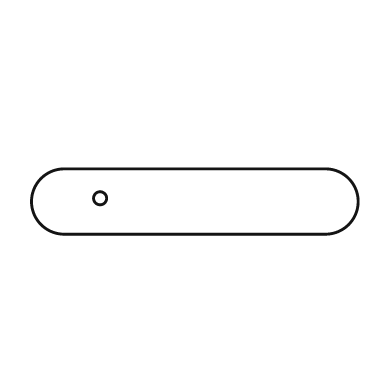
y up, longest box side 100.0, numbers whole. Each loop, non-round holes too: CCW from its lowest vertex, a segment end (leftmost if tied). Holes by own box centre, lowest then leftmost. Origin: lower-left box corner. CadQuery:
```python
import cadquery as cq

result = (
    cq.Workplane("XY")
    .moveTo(10.0, 0.0)
    .lineTo(90.0, 0.0)
    .threePointArc((100.0, 10.0), (90.0, 20.0))
    .lineTo(10.0, 20.0)
    .threePointArc((0.0, 10.0), (10.0, 0.0))
    .close()
    .moveTo(21.0, 11.0)
    .circle(2.0)
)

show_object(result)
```